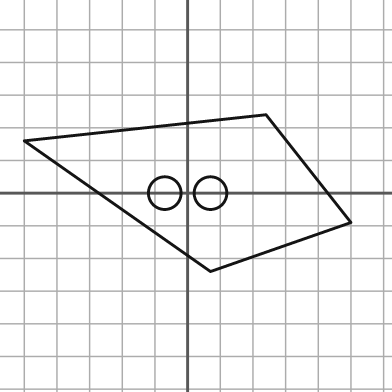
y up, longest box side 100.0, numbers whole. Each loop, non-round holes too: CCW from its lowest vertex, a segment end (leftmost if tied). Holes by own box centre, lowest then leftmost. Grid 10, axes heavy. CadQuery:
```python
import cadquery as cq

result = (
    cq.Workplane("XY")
    .moveTo(7.0, -24.0)
    .lineTo(50.0, -9.0)
    .lineTo(24.0, 24.0)
    .lineTo(-50.0, 16.0)
    .close()
    .moveTo(-7.0, 0.0)
    .circle(5.0)
    .moveTo(7.0, 0.0)
    .circle(5.0)
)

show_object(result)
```